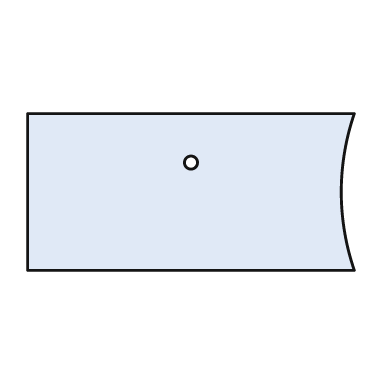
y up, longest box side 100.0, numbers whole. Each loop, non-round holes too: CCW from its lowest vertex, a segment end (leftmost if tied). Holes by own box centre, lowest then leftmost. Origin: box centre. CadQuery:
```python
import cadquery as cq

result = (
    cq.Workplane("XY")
    .moveTo(-50.0, -24.0)
    .lineTo(50.0, -24.0)
    .threePointArc((46.0, 0.0), (50.0, 24.0))
    .lineTo(-50.0, 24.0)
    .close()
    .moveTo(0.0, 9.0)
    .circle(2.0)
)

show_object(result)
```